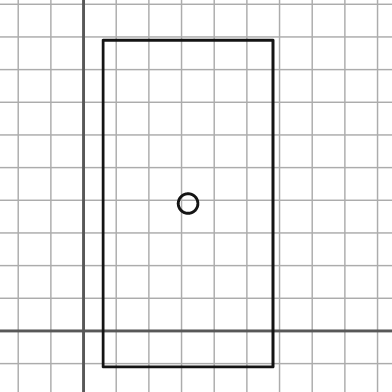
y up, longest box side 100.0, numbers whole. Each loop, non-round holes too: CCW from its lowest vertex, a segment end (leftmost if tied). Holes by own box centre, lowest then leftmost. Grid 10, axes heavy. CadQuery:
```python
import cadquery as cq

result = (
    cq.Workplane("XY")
    .moveTo(6.0, -11.0)
    .lineTo(58.0, -11.0)
    .lineTo(58.0, 89.0)
    .lineTo(6.0, 89.0)
    .close()
    .moveTo(32.0, 39.0)
    .circle(3.0)
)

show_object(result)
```